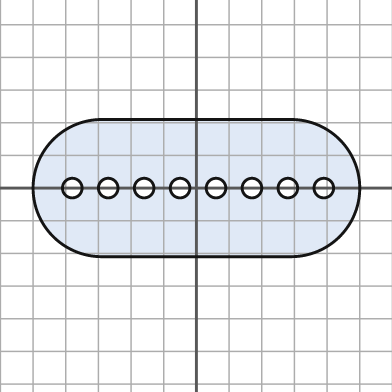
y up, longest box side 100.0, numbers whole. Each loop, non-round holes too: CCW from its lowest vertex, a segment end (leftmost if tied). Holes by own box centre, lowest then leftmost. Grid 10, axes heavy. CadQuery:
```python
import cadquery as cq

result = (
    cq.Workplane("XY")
    .moveTo(-29.0, -21.0)
    .lineTo(29.0, -21.0)
    .threePointArc((50.0, 0.0), (29.0, 21.0))
    .lineTo(-29.0, 21.0)
    .threePointArc((-50.0, 0.0), (-29.0, -21.0))
    .close()
    .moveTo(-38.0, 0.0)
    .circle(3.0)
    .moveTo(-27.0, 0.0)
    .circle(3.0)
    .moveTo(-16.0, 0.0)
    .circle(3.0)
    .moveTo(-5.0, 0.0)
    .circle(3.0)
    .moveTo(6.0, 0.0)
    .circle(3.0)
    .moveTo(17.0, 0.0)
    .circle(3.0)
    .moveTo(28.0, 0.0)
    .circle(3.0)
    .moveTo(39.0, 0.0)
    .circle(3.0)
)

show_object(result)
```